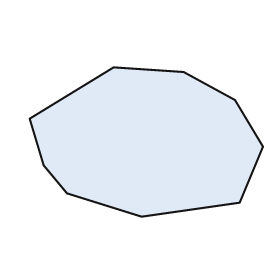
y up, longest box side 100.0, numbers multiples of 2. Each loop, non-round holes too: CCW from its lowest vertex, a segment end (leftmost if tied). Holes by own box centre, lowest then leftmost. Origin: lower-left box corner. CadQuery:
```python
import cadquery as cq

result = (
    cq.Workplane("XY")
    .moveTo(48.0, 0.0)
    .lineTo(90.0, 6.0)
    .lineTo(100.0, 30.0)
    .lineTo(88.0, 50.0)
    .lineTo(66.0, 62.0)
    .lineTo(36.0, 64.0)
    .lineTo(0.0, 42.0)
    .lineTo(6.0, 22.0)
    .lineTo(16.0, 10.0)
    .close()
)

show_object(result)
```